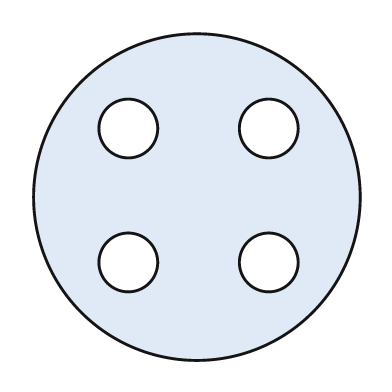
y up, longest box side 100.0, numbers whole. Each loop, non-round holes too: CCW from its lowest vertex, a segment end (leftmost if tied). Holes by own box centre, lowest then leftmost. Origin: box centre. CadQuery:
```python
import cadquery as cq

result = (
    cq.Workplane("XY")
    .moveTo(0.0, 0.0)
    .circle(50.0)
    .moveTo(-21.0, -20.0)
    .circle(9.0)
    .moveTo(22.0, -20.0)
    .circle(9.0)
    .moveTo(-21.0, 21.0)
    .circle(9.0)
    .moveTo(22.0, 21.0)
    .circle(9.0)
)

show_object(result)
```